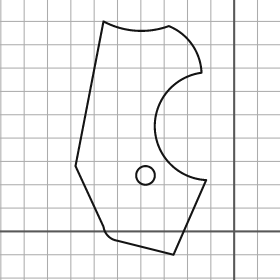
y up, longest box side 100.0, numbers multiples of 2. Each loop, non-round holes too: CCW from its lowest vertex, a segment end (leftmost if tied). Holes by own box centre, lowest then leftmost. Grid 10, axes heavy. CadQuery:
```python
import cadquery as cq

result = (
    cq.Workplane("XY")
    .moveTo(-26.0, -10.0)
    .lineTo(-12.0, 22.0)
    .threePointArc((-34.0, 44.0), (-14.0, 68.0))
    .threePointArc((-18.0, 80.0), (-28.0, 88.0))
    .threePointArc((-42.0, 86.0), (-56.0, 90.0))
    .lineTo(-68.0, 28.0)
    .lineTo(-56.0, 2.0)
    .threePointArc((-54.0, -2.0), (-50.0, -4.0))
    .close()
    .moveTo(-38.0, 24.0)
    .circle(4.0)
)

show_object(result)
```